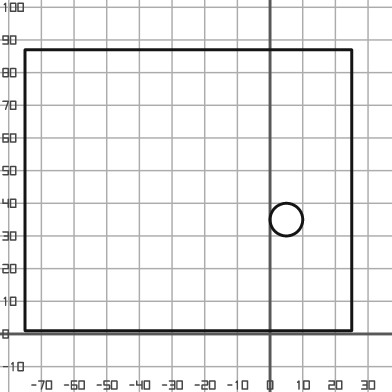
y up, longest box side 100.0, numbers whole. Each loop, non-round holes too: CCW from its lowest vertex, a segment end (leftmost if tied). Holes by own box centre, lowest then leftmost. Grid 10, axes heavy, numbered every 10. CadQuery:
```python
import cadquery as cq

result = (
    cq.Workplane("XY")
    .moveTo(-75.0, 1.0)
    .lineTo(25.0, 1.0)
    .lineTo(25.0, 87.0)
    .lineTo(-75.0, 87.0)
    .close()
    .moveTo(5.0, 35.0)
    .circle(5.0)
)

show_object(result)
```